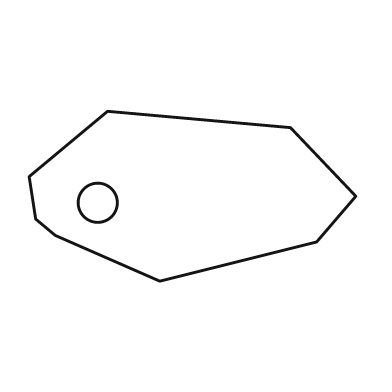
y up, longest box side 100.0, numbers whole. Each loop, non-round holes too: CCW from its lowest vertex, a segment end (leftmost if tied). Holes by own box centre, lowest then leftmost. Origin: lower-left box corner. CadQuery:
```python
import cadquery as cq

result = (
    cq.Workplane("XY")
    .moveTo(40.0, 0.0)
    .lineTo(88.0, 12.0)
    .lineTo(100.0, 26.0)
    .lineTo(80.0, 47.0)
    .lineTo(24.0, 52.0)
    .lineTo(0.0, 32.0)
    .lineTo(2.0, 19.0)
    .lineTo(8.0, 14.0)
    .close()
    .moveTo(21.0, 24.0)
    .circle(6.0)
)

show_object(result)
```